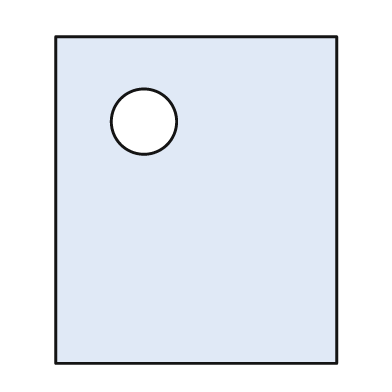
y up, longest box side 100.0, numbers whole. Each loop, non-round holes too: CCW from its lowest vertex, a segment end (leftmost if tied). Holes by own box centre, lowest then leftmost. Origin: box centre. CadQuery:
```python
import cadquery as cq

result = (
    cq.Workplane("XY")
    .moveTo(-43.0, -50.0)
    .lineTo(43.0, -50.0)
    .lineTo(43.0, 50.0)
    .lineTo(-43.0, 50.0)
    .close()
    .moveTo(-16.0, 24.0)
    .circle(10.0)
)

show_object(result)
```